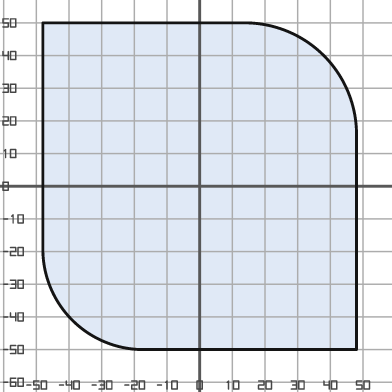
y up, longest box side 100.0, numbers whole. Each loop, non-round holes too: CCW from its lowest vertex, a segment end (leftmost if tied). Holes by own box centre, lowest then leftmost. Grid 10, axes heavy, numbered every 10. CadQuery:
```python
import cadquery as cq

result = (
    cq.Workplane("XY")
    .moveTo(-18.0, -50.0)
    .lineTo(48.0, -50.0)
    .lineTo(48.0, 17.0)
    .threePointArc((38.0, 40.0), (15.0, 50.0))
    .lineTo(-48.0, 50.0)
    .lineTo(-48.0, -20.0)
    .threePointArc((-39.0, -41.0), (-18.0, -50.0))
    .close()
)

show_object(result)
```